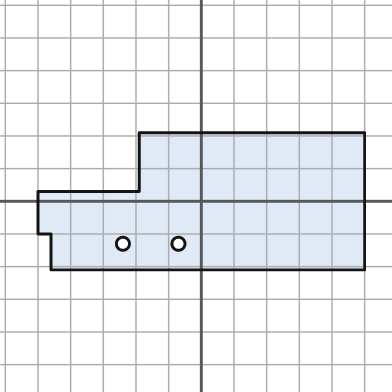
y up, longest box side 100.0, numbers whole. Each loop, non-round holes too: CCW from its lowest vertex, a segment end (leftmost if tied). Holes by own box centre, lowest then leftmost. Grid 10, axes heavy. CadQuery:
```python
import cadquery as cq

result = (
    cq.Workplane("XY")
    .moveTo(-46.0, -21.0)
    .lineTo(50.0, -21.0)
    .lineTo(50.0, 21.0)
    .lineTo(-19.0, 21.0)
    .lineTo(-19.0, 3.0)
    .lineTo(-50.0, 3.0)
    .lineTo(-50.0, -10.0)
    .lineTo(-46.0, -10.0)
    .close()
    .moveTo(-24.0, -13.0)
    .circle(2.0)
    .moveTo(-7.0, -13.0)
    .circle(2.0)
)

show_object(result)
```